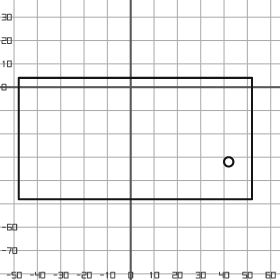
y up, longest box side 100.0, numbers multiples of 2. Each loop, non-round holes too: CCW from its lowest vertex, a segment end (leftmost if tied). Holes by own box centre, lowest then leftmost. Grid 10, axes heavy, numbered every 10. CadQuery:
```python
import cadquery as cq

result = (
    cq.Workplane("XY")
    .moveTo(-48.0, -48.0)
    .lineTo(52.0, -48.0)
    .lineTo(52.0, 4.0)
    .lineTo(-48.0, 4.0)
    .close()
    .moveTo(42.0, -32.0)
    .circle(2.0)
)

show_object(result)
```